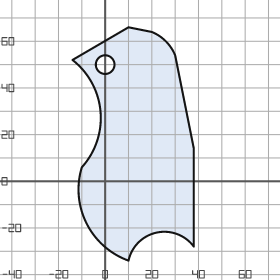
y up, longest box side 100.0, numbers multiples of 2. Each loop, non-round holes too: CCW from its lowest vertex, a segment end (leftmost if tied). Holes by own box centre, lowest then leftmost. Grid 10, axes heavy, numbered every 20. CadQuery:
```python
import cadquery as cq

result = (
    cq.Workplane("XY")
    .moveTo(10.0, -34.0)
    .threePointArc((22.0, -22.0), (38.0, -28.0))
    .lineTo(38.0, 14.0)
    .lineTo(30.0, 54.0)
    .threePointArc((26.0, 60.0), (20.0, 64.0))
    .lineTo(10.0, 66.0)
    .lineTo(-14.0, 52.0)
    .threePointArc((-2.0, 30.0), (-10.0, 6.0))
    .threePointArc((-8.0, -18.0), (10.0, -34.0))
    .close()
    .moveTo(0.0, 50.0)
    .circle(4.0)
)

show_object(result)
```